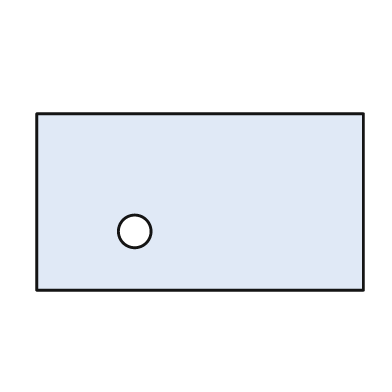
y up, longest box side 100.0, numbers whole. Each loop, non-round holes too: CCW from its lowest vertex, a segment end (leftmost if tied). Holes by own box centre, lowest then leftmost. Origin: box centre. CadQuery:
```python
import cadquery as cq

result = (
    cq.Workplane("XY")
    .moveTo(-50.0, -27.0)
    .lineTo(50.0, -27.0)
    .lineTo(50.0, 27.0)
    .lineTo(-50.0, 27.0)
    .close()
    .moveTo(-20.0, -9.0)
    .circle(5.0)
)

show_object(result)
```